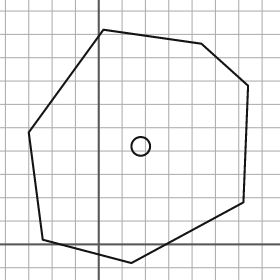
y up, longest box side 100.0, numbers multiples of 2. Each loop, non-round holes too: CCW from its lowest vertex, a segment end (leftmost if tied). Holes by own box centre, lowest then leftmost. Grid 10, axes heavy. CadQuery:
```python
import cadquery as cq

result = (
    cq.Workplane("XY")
    .moveTo(14.0, -8.0)
    .lineTo(62.0, 18.0)
    .lineTo(64.0, 68.0)
    .lineTo(44.0, 86.0)
    .lineTo(2.0, 92.0)
    .lineTo(-30.0, 48.0)
    .lineTo(-24.0, 2.0)
    .close()
    .moveTo(18.0, 42.0)
    .circle(4.0)
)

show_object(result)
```